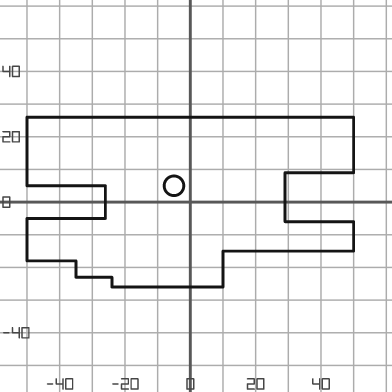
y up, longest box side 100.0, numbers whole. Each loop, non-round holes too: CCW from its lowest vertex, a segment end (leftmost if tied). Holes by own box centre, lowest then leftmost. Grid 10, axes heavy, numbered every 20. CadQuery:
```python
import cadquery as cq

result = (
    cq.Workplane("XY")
    .moveTo(-24.0, -26.0)
    .lineTo(10.0, -26.0)
    .lineTo(10.0, -15.0)
    .lineTo(50.0, -15.0)
    .lineTo(50.0, -6.0)
    .lineTo(29.0, -6.0)
    .lineTo(29.0, 9.0)
    .lineTo(50.0, 9.0)
    .lineTo(50.0, 26.0)
    .lineTo(-50.0, 26.0)
    .lineTo(-50.0, 5.0)
    .lineTo(-26.0, 5.0)
    .lineTo(-26.0, -5.0)
    .lineTo(-50.0, -5.0)
    .lineTo(-50.0, -18.0)
    .lineTo(-35.0, -18.0)
    .lineTo(-35.0, -23.0)
    .lineTo(-24.0, -23.0)
    .close()
    .moveTo(-5.0, 5.0)
    .circle(3.0)
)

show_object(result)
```